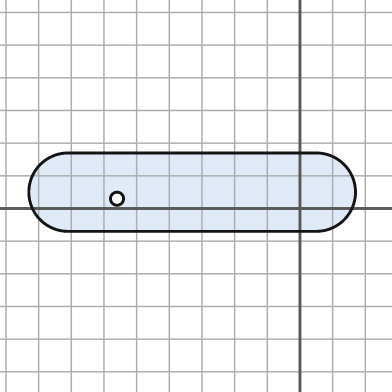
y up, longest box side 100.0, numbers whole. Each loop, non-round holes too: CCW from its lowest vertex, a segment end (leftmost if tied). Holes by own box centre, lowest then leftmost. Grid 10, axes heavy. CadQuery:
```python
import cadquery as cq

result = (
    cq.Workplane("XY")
    .moveTo(-71.0, -7.0)
    .lineTo(5.0, -7.0)
    .threePointArc((17.0, 5.0), (5.0, 17.0))
    .lineTo(-71.0, 17.0)
    .threePointArc((-83.0, 5.0), (-71.0, -7.0))
    .close()
    .moveTo(-56.0, 3.0)
    .circle(2.0)
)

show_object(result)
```